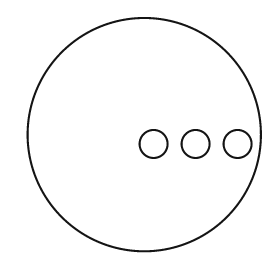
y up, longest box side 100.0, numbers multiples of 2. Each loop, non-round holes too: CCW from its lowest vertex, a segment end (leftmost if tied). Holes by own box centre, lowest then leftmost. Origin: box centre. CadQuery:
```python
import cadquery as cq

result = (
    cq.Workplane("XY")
    .moveTo(0.0, 0.0)
    .circle(50.0)
    .moveTo(4.0, -4.0)
    .circle(6.0)
    .moveTo(22.0, -4.0)
    .circle(6.0)
    .moveTo(40.0, -4.0)
    .circle(6.0)
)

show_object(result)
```